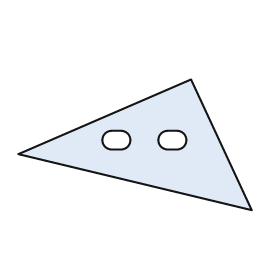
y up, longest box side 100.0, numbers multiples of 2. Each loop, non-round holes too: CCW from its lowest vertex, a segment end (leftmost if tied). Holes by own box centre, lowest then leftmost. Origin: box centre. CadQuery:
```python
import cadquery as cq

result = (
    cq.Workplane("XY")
    .moveTo(50.0, -28.0)
    .lineTo(24.0, 28.0)
    .lineTo(-50.0, -4.0)
    .close()
    .moveTo(-10.0, -2.0)
    .lineTo(-6.0, -2.0)
    .threePointArc((-2.0, 2.0), (-6.0, 6.0))
    .lineTo(-10.0, 6.0)
    .threePointArc((-14.0, 2.0), (-10.0, -2.0))
    .close()
    .moveTo(14.0, -2.0)
    .lineTo(18.0, -2.0)
    .threePointArc((22.0, 2.0), (18.0, 6.0))
    .lineTo(14.0, 6.0)
    .threePointArc((10.0, 2.0), (14.0, -2.0))
    .close()
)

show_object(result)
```